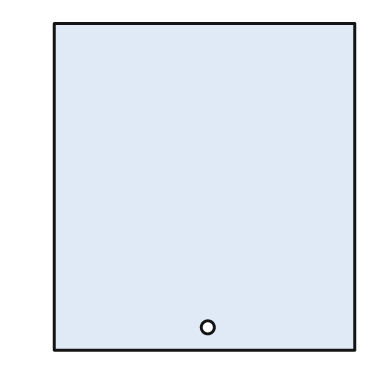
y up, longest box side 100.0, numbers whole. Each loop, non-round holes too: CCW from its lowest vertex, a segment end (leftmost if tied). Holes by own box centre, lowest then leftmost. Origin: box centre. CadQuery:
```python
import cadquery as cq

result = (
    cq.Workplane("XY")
    .moveTo(-46.0, -50.0)
    .lineTo(46.0, -50.0)
    .lineTo(46.0, 50.0)
    .lineTo(-46.0, 50.0)
    .close()
    .moveTo(1.0, -43.0)
    .circle(2.0)
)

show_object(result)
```